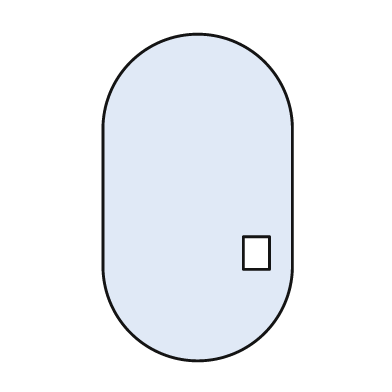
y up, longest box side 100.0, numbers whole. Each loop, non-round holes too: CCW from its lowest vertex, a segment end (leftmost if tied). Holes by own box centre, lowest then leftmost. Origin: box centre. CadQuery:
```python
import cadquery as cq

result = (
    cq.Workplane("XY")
    .moveTo(-29.0, -21.0)
    .threePointArc((0.0, -50.0), (29.0, -21.0))
    .lineTo(29.0, 21.0)
    .threePointArc((0.0, 50.0), (-29.0, 21.0))
    .close()
    .moveTo(14.0, -22.0)
    .lineTo(22.0, -22.0)
    .lineTo(22.0, -12.0)
    .lineTo(14.0, -12.0)
    .close()
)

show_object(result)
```